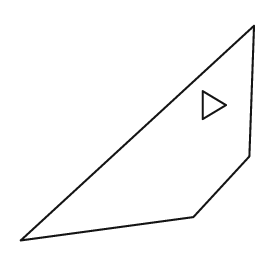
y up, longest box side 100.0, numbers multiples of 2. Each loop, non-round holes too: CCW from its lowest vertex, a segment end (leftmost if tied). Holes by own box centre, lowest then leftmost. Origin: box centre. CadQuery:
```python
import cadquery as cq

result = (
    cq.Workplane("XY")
    .moveTo(-50.0, -46.0)
    .lineTo(24.0, -36.0)
    .lineTo(48.0, -10.0)
    .lineTo(50.0, 46.0)
    .close()
    .moveTo(28.0, 6.0)
    .lineTo(38.0, 12.0)
    .lineTo(28.0, 18.0)
    .close()
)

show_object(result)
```